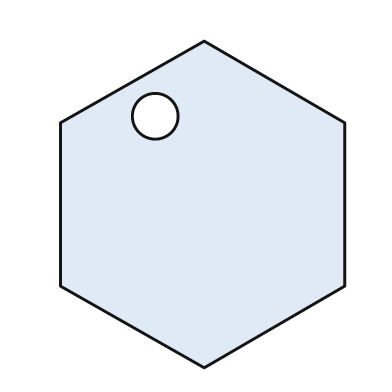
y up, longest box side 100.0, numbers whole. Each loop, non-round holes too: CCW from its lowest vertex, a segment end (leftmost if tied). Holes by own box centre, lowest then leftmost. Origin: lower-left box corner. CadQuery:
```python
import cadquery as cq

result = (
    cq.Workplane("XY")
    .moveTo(44.0, 0.0)
    .lineTo(87.0, 25.0)
    .lineTo(87.0, 75.0)
    .lineTo(44.0, 100.0)
    .lineTo(0.0, 75.0)
    .lineTo(0.0, 25.0)
    .close()
    .moveTo(29.0, 77.0)
    .circle(7.0)
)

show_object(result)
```